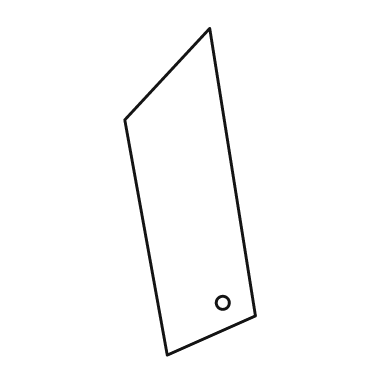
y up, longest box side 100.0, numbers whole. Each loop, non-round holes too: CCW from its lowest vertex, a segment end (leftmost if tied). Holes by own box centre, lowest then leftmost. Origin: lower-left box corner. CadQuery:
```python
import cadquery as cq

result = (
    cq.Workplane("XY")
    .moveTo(13.0, 0.0)
    .lineTo(40.0, 12.0)
    .lineTo(26.0, 100.0)
    .lineTo(0.0, 72.0)
    .close()
    .moveTo(30.0, 16.0)
    .circle(2.0)
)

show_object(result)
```